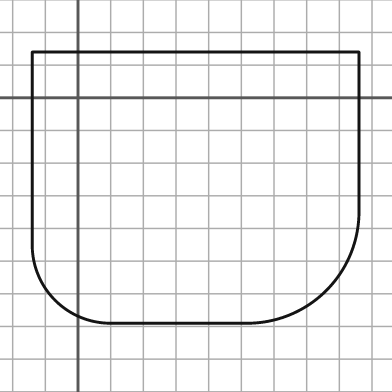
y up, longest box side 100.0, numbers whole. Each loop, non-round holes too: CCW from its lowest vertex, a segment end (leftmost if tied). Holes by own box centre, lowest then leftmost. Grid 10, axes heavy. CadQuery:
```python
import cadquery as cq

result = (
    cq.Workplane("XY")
    .moveTo(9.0, -69.0)
    .lineTo(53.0, -69.0)
    .threePointArc((76.0, -59.0), (86.0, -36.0))
    .lineTo(86.0, 14.0)
    .lineTo(-14.0, 14.0)
    .lineTo(-14.0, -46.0)
    .threePointArc((-7.0, -62.0), (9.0, -69.0))
    .close()
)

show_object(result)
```